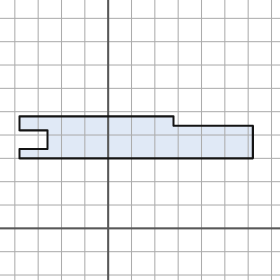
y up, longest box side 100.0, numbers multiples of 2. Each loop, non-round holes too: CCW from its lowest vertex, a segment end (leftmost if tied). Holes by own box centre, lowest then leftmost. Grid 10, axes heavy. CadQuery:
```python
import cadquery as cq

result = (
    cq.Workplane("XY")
    .moveTo(-38.0, 30.0)
    .lineTo(62.0, 30.0)
    .lineTo(62.0, 44.0)
    .lineTo(28.0, 44.0)
    .lineTo(28.0, 48.0)
    .lineTo(-38.0, 48.0)
    .lineTo(-38.0, 42.0)
    .lineTo(-26.0, 42.0)
    .lineTo(-26.0, 34.0)
    .lineTo(-38.0, 34.0)
    .close()
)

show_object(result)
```